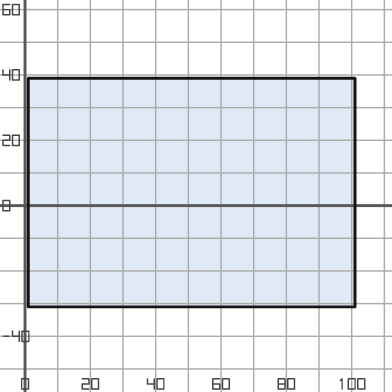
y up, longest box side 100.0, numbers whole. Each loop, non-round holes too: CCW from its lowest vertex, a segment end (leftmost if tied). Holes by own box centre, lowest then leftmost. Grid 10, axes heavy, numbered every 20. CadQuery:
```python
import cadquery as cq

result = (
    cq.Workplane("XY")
    .moveTo(1.0, -31.0)
    .lineTo(101.0, -31.0)
    .lineTo(101.0, 39.0)
    .lineTo(1.0, 39.0)
    .close()
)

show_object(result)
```